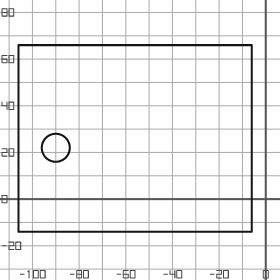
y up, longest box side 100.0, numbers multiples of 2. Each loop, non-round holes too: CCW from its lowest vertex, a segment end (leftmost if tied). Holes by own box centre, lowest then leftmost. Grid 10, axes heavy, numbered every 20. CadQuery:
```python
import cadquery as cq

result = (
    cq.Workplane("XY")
    .moveTo(-106.0, -14.0)
    .lineTo(-6.0, -14.0)
    .lineTo(-6.0, 66.0)
    .lineTo(-106.0, 66.0)
    .close()
    .moveTo(-90.0, 22.0)
    .circle(6.0)
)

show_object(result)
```